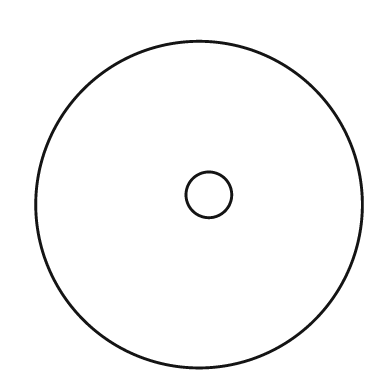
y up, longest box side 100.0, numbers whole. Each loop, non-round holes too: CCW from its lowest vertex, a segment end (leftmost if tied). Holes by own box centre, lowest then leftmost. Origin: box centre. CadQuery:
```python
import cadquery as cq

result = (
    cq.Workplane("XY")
    .moveTo(0.0, 0.0)
    .circle(50.0)
    .moveTo(3.0, 3.0)
    .circle(7.0)
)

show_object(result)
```